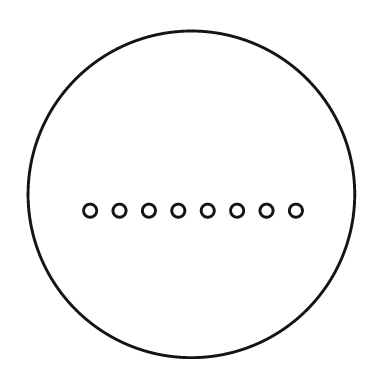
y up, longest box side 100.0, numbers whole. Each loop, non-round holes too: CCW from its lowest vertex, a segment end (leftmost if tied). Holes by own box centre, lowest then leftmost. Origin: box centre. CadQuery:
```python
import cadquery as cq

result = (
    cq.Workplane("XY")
    .moveTo(0.0, 0.0)
    .circle(50.0)
    .moveTo(-31.0, -5.0)
    .circle(2.0)
    .moveTo(-22.0, -5.0)
    .circle(2.0)
    .moveTo(-13.0, -5.0)
    .circle(2.0)
    .moveTo(-4.0, -5.0)
    .circle(2.0)
    .moveTo(5.0, -5.0)
    .circle(2.0)
    .moveTo(14.0, -5.0)
    .circle(2.0)
    .moveTo(23.0, -5.0)
    .circle(2.0)
    .moveTo(32.0, -5.0)
    .circle(2.0)
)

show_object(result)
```